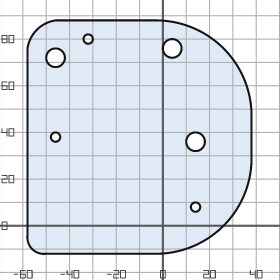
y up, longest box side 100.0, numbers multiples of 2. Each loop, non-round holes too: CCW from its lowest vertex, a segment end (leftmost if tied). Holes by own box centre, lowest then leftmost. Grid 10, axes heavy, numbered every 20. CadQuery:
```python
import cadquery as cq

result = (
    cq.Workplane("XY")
    .moveTo(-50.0, -12.0)
    .lineTo(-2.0, -12.0)
    .threePointArc((26.0, 0.0), (38.0, 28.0))
    .lineTo(38.0, 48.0)
    .threePointArc((26.0, 76.0), (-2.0, 88.0))
    .lineTo(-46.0, 88.0)
    .threePointArc((-54.0, 84.0), (-58.0, 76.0))
    .lineTo(-58.0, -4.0)
    .threePointArc((-56.0, -10.0), (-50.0, -12.0))
    .close()
    .moveTo(14.0, 8.0)
    .circle(2.0)
    .moveTo(14.0, 36.0)
    .circle(4.0)
    .moveTo(-46.0, 38.0)
    .circle(2.0)
    .moveTo(-46.0, 72.0)
    .circle(4.0)
    .moveTo(4.0, 76.0)
    .circle(4.0)
    .moveTo(-32.0, 80.0)
    .circle(2.0)
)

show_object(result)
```